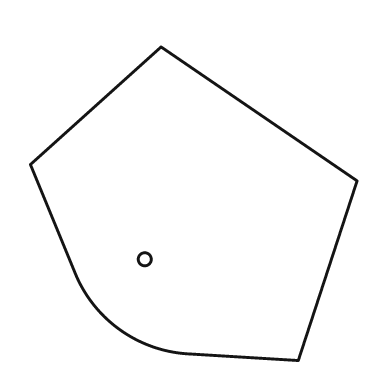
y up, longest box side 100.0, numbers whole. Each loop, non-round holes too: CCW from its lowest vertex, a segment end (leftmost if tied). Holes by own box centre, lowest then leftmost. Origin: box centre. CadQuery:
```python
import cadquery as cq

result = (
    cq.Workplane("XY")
    .moveTo(32.0, -48.0)
    .lineTo(50.0, 7.0)
    .lineTo(-10.0, 48.0)
    .lineTo(-50.0, 12.0)
    .lineTo(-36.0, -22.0)
    .threePointArc((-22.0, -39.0), (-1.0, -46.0))
    .close()
    .moveTo(-15.0, -17.0)
    .circle(2.0)
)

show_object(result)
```